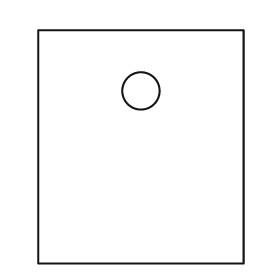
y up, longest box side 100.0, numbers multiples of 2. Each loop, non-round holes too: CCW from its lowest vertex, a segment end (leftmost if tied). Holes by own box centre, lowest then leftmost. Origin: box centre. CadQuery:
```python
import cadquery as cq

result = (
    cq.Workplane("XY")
    .moveTo(-44.0, -50.0)
    .lineTo(44.0, -50.0)
    .lineTo(44.0, 50.0)
    .lineTo(-44.0, 50.0)
    .close()
    .moveTo(0.0, 24.0)
    .circle(8.0)
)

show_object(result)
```